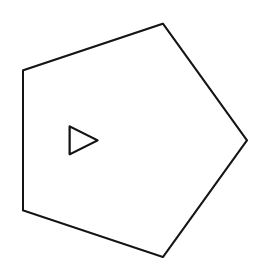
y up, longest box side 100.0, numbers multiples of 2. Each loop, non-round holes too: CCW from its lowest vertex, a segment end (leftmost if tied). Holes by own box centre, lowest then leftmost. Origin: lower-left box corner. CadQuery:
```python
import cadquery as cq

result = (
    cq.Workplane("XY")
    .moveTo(60.0, 0.0)
    .lineTo(96.0, 50.0)
    .lineTo(60.0, 100.0)
    .lineTo(0.0, 80.0)
    .lineTo(0.0, 20.0)
    .close()
    .moveTo(20.0, 44.0)
    .lineTo(32.0, 50.0)
    .lineTo(20.0, 56.0)
    .close()
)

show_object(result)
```